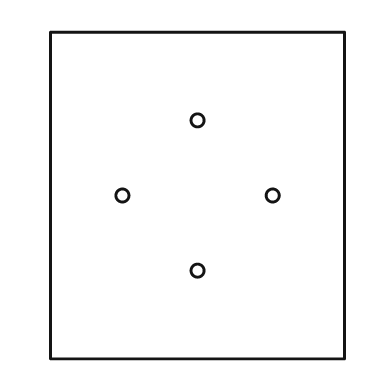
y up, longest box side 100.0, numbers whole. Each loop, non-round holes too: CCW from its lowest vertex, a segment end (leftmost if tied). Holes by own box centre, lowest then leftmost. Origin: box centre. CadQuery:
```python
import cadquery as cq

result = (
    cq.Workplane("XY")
    .moveTo(-45.0, -50.0)
    .lineTo(45.0, -50.0)
    .lineTo(45.0, 50.0)
    .lineTo(-45.0, 50.0)
    .close()
    .moveTo(0.0, -23.0)
    .circle(2.0)
    .moveTo(-23.0, 0.0)
    .circle(2.0)
    .moveTo(23.0, 0.0)
    .circle(2.0)
    .moveTo(0.0, 23.0)
    .circle(2.0)
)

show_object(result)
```